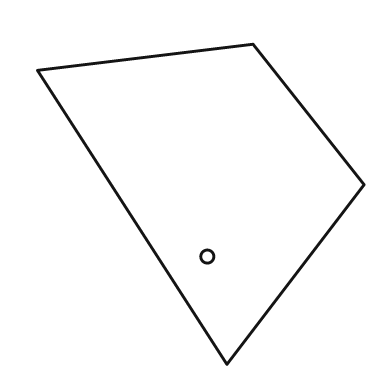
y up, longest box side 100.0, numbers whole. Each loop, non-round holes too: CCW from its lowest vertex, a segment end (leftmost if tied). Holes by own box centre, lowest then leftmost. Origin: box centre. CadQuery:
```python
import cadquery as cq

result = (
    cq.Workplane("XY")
    .moveTo(8.0, -49.0)
    .lineTo(50.0, 6.0)
    .lineTo(16.0, 49.0)
    .lineTo(-50.0, 41.0)
    .close()
    .moveTo(2.0, -16.0)
    .circle(2.0)
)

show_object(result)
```